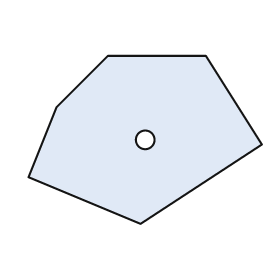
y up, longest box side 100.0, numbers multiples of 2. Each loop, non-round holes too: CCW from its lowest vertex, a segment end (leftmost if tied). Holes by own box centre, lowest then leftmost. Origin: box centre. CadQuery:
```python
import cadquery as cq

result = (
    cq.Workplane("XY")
    .moveTo(-2.0, -36.0)
    .lineTo(50.0, -2.0)
    .lineTo(26.0, 36.0)
    .lineTo(-16.0, 36.0)
    .lineTo(-38.0, 14.0)
    .lineTo(-50.0, -16.0)
    .close()
    .moveTo(0.0, 0.0)
    .circle(4.0)
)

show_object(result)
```